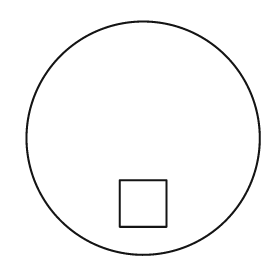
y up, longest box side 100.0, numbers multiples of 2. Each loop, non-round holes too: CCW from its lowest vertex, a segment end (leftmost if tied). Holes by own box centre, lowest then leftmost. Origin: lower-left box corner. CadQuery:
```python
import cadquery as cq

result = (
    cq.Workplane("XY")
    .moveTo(50.0, 50.0)
    .circle(50.0)
    .moveTo(40.0, 12.0)
    .lineTo(60.0, 12.0)
    .lineTo(60.0, 32.0)
    .lineTo(40.0, 32.0)
    .close()
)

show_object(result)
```